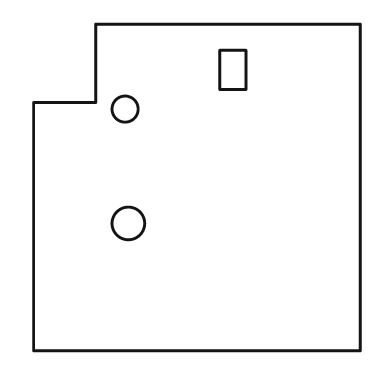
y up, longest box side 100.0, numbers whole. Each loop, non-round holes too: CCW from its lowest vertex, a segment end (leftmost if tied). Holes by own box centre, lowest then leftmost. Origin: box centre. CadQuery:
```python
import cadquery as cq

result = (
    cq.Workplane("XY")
    .moveTo(-50.0, -50.0)
    .lineTo(50.0, -50.0)
    .lineTo(50.0, 50.0)
    .lineTo(-31.0, 50.0)
    .lineTo(-31.0, 26.0)
    .lineTo(-50.0, 26.0)
    .close()
    .moveTo(-21.0, -11.0)
    .circle(5.0)
    .moveTo(-22.0, 24.0)
    .circle(4.0)
    .moveTo(7.0, 30.0)
    .lineTo(15.0, 30.0)
    .lineTo(15.0, 42.0)
    .lineTo(7.0, 42.0)
    .close()
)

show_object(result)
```